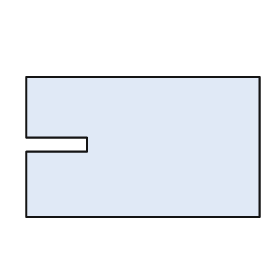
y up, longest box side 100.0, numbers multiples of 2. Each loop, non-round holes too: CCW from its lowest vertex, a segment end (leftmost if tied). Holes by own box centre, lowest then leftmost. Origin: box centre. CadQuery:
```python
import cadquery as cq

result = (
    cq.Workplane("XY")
    .moveTo(-50.0, -30.0)
    .lineTo(50.0, -30.0)
    .lineTo(50.0, 30.0)
    .lineTo(-50.0, 30.0)
    .lineTo(-50.0, 4.0)
    .lineTo(-24.0, 4.0)
    .lineTo(-24.0, -2.0)
    .lineTo(-50.0, -2.0)
    .close()
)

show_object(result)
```